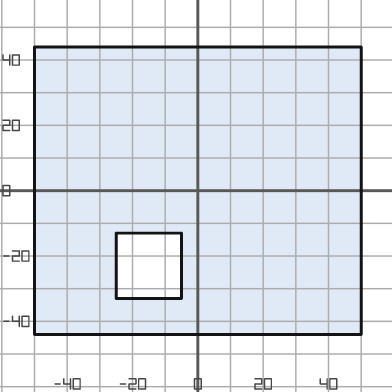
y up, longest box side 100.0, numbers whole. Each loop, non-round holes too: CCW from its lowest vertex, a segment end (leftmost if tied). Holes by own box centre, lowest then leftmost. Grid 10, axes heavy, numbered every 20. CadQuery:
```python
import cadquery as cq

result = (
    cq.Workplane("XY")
    .moveTo(-50.0, -44.0)
    .lineTo(50.0, -44.0)
    .lineTo(50.0, 44.0)
    .lineTo(-50.0, 44.0)
    .close()
    .moveTo(-25.0, -33.0)
    .lineTo(-5.0, -33.0)
    .lineTo(-5.0, -13.0)
    .lineTo(-25.0, -13.0)
    .close()
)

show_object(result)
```